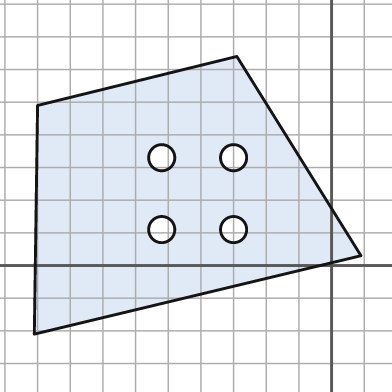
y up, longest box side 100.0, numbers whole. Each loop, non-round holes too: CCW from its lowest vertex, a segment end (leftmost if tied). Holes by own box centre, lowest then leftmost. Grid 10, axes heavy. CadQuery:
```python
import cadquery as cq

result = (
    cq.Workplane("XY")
    .moveTo(-91.0, -21.0)
    .lineTo(9.0, 3.0)
    .lineTo(-29.0, 64.0)
    .lineTo(-90.0, 49.0)
    .close()
    .moveTo(-52.0, 11.0)
    .circle(4.0)
    .moveTo(-30.0, 11.0)
    .circle(4.0)
    .moveTo(-52.0, 33.0)
    .circle(4.0)
    .moveTo(-30.0, 33.0)
    .circle(4.0)
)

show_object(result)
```